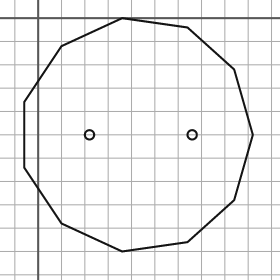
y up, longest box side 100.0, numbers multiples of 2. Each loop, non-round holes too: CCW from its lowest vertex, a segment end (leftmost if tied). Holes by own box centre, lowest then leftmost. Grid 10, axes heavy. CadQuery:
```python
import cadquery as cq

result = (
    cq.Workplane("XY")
    .moveTo(36.0, -100.0)
    .lineTo(64.0, -96.0)
    .lineTo(84.0, -78.0)
    .lineTo(92.0, -50.0)
    .lineTo(84.0, -22.0)
    .lineTo(64.0, -4.0)
    .lineTo(36.0, 0.0)
    .lineTo(10.0, -12.0)
    .lineTo(-6.0, -36.0)
    .lineTo(-6.0, -64.0)
    .lineTo(10.0, -88.0)
    .close()
    .moveTo(22.0, -50.0)
    .circle(2.0)
    .moveTo(66.0, -50.0)
    .circle(2.0)
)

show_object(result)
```